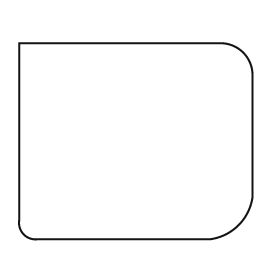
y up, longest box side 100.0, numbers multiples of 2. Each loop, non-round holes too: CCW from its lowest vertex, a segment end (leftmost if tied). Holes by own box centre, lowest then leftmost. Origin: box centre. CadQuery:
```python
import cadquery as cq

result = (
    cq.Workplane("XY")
    .moveTo(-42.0, -42.0)
    .lineTo(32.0, -42.0)
    .threePointArc((44.0, -36.0), (50.0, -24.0))
    .lineTo(50.0, 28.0)
    .threePointArc((46.0, 38.0), (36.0, 42.0))
    .lineTo(-50.0, 42.0)
    .lineTo(-50.0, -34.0)
    .threePointArc((-48.0, -40.0), (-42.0, -42.0))
    .close()
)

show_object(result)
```